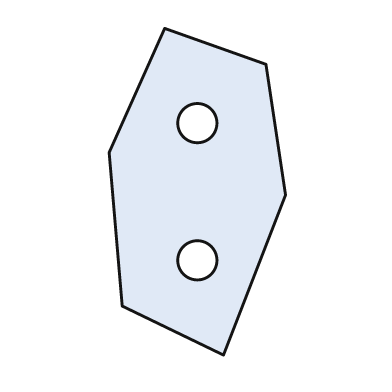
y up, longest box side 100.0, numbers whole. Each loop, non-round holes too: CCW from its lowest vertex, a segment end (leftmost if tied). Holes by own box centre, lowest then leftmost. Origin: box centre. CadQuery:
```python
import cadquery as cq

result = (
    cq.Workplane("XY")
    .moveTo(8.0, -50.0)
    .lineTo(27.0, -1.0)
    .lineTo(21.0, 39.0)
    .lineTo(-10.0, 50.0)
    .lineTo(-27.0, 12.0)
    .lineTo(-23.0, -35.0)
    .close()
    .moveTo(0.0, -21.0)
    .circle(6.0)
    .moveTo(0.0, 21.0)
    .circle(6.0)
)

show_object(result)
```